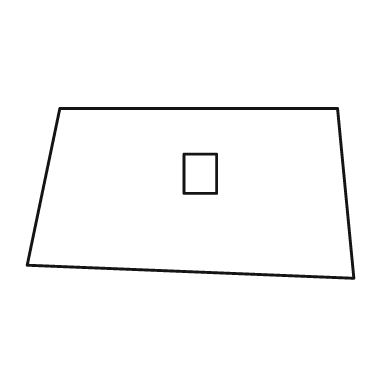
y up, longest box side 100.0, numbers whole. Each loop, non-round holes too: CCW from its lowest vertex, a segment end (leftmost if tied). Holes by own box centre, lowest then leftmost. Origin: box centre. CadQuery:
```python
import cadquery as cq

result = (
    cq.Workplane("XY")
    .moveTo(50.0, -26.0)
    .lineTo(45.0, 26.0)
    .lineTo(-40.0, 26.0)
    .lineTo(-50.0, -22.0)
    .close()
    .moveTo(-2.0, 0.0)
    .lineTo(8.0, 0.0)
    .lineTo(8.0, 12.0)
    .lineTo(-2.0, 12.0)
    .close()
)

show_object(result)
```